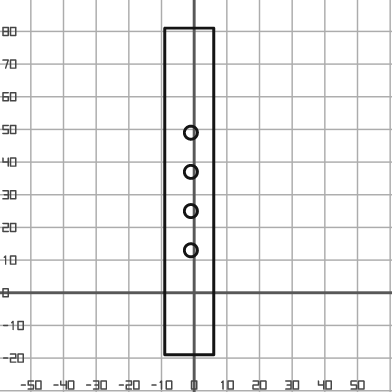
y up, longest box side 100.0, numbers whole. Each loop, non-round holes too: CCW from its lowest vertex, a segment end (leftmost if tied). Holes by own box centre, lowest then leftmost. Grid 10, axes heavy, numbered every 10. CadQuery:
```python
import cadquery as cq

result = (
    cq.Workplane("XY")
    .moveTo(-9.0, -19.0)
    .lineTo(6.0, -19.0)
    .lineTo(6.0, 81.0)
    .lineTo(-9.0, 81.0)
    .close()
    .moveTo(-1.0, 13.0)
    .circle(2.0)
    .moveTo(-1.0, 25.0)
    .circle(2.0)
    .moveTo(-1.0, 37.0)
    .circle(2.0)
    .moveTo(-1.0, 49.0)
    .circle(2.0)
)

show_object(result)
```